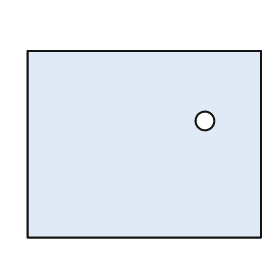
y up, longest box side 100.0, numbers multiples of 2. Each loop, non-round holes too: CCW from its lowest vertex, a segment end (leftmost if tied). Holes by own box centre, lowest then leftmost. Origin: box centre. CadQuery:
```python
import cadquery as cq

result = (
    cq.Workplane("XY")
    .moveTo(-50.0, -40.0)
    .lineTo(50.0, -40.0)
    .lineTo(50.0, 40.0)
    .lineTo(-50.0, 40.0)
    .close()
    .moveTo(26.0, 10.0)
    .circle(4.0)
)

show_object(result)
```